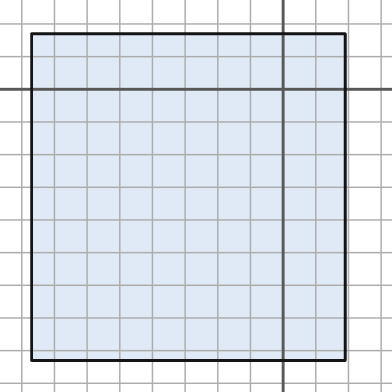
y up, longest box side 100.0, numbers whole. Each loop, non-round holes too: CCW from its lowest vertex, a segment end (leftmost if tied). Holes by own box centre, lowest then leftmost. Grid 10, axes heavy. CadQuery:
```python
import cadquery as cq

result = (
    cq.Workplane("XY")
    .moveTo(-77.0, -83.0)
    .lineTo(19.0, -83.0)
    .lineTo(19.0, 17.0)
    .lineTo(-77.0, 17.0)
    .close()
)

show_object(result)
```